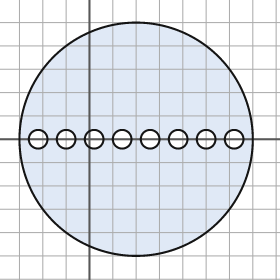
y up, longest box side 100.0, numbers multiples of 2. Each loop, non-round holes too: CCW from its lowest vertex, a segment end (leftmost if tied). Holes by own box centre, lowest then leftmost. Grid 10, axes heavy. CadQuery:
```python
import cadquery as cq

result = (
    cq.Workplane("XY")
    .moveTo(20.0, 0.0)
    .circle(50.0)
    .moveTo(-22.0, 0.0)
    .circle(4.0)
    .moveTo(-10.0, 0.0)
    .circle(4.0)
    .moveTo(2.0, 0.0)
    .circle(4.0)
    .moveTo(14.0, 0.0)
    .circle(4.0)
    .moveTo(26.0, 0.0)
    .circle(4.0)
    .moveTo(38.0, 0.0)
    .circle(4.0)
    .moveTo(50.0, 0.0)
    .circle(4.0)
    .moveTo(62.0, 0.0)
    .circle(4.0)
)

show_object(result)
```